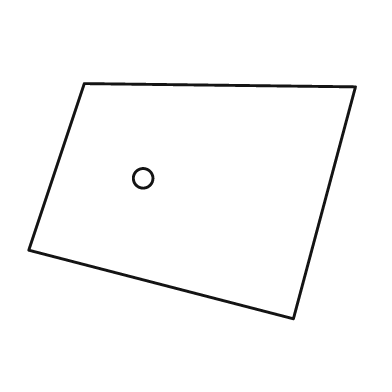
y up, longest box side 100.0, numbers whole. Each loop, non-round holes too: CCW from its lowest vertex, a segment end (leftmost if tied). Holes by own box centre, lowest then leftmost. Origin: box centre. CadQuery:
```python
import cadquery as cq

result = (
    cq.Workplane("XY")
    .moveTo(31.0, -36.0)
    .lineTo(50.0, 35.0)
    .lineTo(-33.0, 36.0)
    .lineTo(-50.0, -15.0)
    .close()
    .moveTo(-15.0, 7.0)
    .circle(3.0)
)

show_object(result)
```